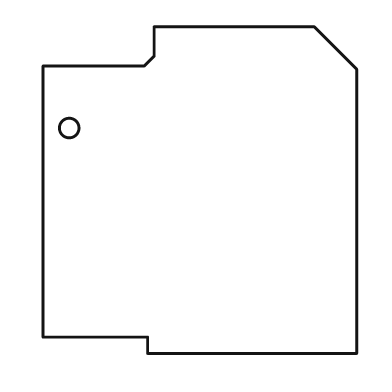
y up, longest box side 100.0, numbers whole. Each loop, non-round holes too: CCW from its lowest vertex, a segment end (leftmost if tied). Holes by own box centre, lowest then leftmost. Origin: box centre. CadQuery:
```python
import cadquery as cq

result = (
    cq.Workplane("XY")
    .moveTo(-16.0, -50.0)
    .lineTo(48.0, -50.0)
    .lineTo(48.0, 37.0)
    .lineTo(35.0, 50.0)
    .lineTo(-14.0, 50.0)
    .lineTo(-14.0, 41.0)
    .lineTo(-17.0, 38.0)
    .lineTo(-48.0, 38.0)
    .lineTo(-48.0, -45.0)
    .lineTo(-16.0, -45.0)
    .close()
    .moveTo(-40.0, 19.0)
    .circle(3.0)
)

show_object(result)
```